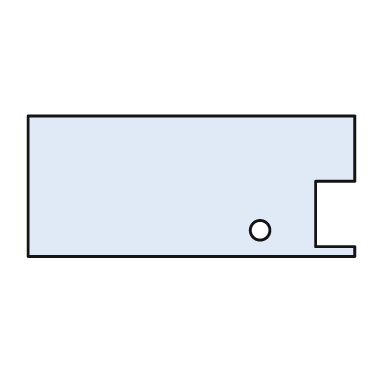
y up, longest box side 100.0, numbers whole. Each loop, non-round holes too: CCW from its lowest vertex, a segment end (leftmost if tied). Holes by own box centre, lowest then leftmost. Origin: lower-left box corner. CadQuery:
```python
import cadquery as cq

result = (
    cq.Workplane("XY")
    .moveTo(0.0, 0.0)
    .lineTo(100.0, 0.0)
    .lineTo(100.0, 3.0)
    .lineTo(88.0, 3.0)
    .lineTo(88.0, 23.0)
    .lineTo(100.0, 23.0)
    .lineTo(100.0, 43.0)
    .lineTo(0.0, 43.0)
    .close()
    .moveTo(71.0, 8.0)
    .circle(3.0)
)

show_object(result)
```